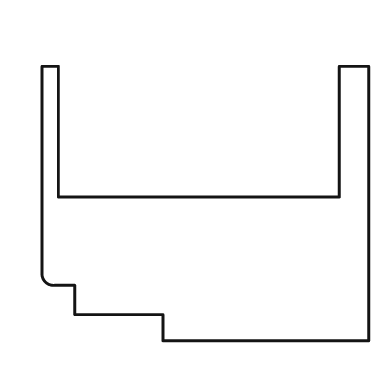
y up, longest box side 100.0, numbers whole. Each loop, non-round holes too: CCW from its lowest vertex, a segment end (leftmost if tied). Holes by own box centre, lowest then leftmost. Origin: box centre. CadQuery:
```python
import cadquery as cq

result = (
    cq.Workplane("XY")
    .moveTo(-13.0, -42.0)
    .lineTo(50.0, -42.0)
    .lineTo(50.0, 42.0)
    .lineTo(41.0, 42.0)
    .lineTo(41.0, 2.0)
    .lineTo(-45.0, 2.0)
    .lineTo(-45.0, 42.0)
    .lineTo(-50.0, 42.0)
    .lineTo(-50.0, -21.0)
    .threePointArc((-49.0, -24.0), (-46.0, -25.0))
    .lineTo(-40.0, -25.0)
    .lineTo(-40.0, -34.0)
    .lineTo(-13.0, -34.0)
    .close()
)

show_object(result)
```